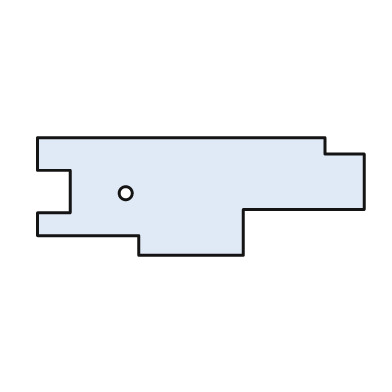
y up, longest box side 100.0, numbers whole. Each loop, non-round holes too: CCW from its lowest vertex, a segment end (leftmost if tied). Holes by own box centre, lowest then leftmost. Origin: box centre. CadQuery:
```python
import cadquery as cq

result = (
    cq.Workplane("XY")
    .moveTo(-19.0, -18.0)
    .lineTo(13.0, -18.0)
    .lineTo(13.0, -4.0)
    .lineTo(50.0, -4.0)
    .lineTo(50.0, 13.0)
    .lineTo(38.0, 13.0)
    .lineTo(38.0, 18.0)
    .lineTo(-50.0, 18.0)
    .lineTo(-50.0, 8.0)
    .lineTo(-40.0, 8.0)
    .lineTo(-40.0, -5.0)
    .lineTo(-50.0, -5.0)
    .lineTo(-50.0, -12.0)
    .lineTo(-19.0, -12.0)
    .close()
    .moveTo(-23.0, 1.0)
    .circle(2.0)
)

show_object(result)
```